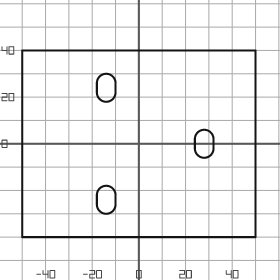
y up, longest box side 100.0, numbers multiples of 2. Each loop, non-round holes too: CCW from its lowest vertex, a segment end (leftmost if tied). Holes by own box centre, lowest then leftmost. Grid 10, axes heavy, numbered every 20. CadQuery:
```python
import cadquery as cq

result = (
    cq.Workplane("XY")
    .moveTo(-50.0, -40.0)
    .lineTo(50.0, -40.0)
    .lineTo(50.0, 40.0)
    .lineTo(-50.0, 40.0)
    .close()
    .moveTo(-18.0, -26.0)
    .threePointArc((-14.0, -30.0), (-10.0, -26.0))
    .lineTo(-10.0, -22.0)
    .threePointArc((-14.0, -18.0), (-18.0, -22.0))
    .close()
    .moveTo(24.0, -2.0)
    .threePointArc((28.0, -6.0), (32.0, -2.0))
    .lineTo(32.0, 2.0)
    .threePointArc((28.0, 6.0), (24.0, 2.0))
    .close()
    .moveTo(-18.0, 22.0)
    .threePointArc((-14.0, 18.0), (-10.0, 22.0))
    .lineTo(-10.0, 26.0)
    .threePointArc((-14.0, 30.0), (-18.0, 26.0))
    .close()
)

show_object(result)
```